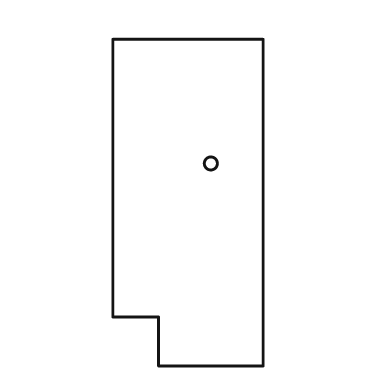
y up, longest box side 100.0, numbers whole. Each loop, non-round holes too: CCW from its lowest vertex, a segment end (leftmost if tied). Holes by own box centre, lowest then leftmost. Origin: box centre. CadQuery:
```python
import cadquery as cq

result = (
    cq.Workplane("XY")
    .moveTo(-9.0, -50.0)
    .lineTo(23.0, -50.0)
    .lineTo(23.0, 50.0)
    .lineTo(-23.0, 50.0)
    .lineTo(-23.0, -35.0)
    .lineTo(-9.0, -35.0)
    .close()
    .moveTo(7.0, 12.0)
    .circle(2.0)
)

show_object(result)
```